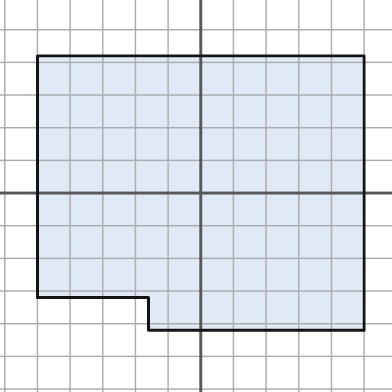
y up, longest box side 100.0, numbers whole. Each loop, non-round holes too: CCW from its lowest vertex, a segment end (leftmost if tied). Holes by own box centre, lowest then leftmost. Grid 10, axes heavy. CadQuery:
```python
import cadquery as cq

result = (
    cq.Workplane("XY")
    .moveTo(-16.0, -42.0)
    .lineTo(50.0, -42.0)
    .lineTo(50.0, 42.0)
    .lineTo(-50.0, 42.0)
    .lineTo(-50.0, -32.0)
    .lineTo(-16.0, -32.0)
    .close()
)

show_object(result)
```